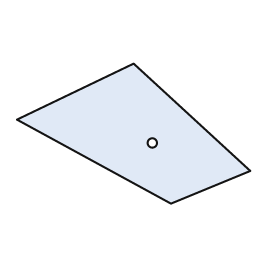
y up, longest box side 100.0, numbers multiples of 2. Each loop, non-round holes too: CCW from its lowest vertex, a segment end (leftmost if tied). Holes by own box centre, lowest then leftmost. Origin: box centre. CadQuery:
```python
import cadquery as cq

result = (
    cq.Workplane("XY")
    .moveTo(16.0, -30.0)
    .lineTo(50.0, -16.0)
    .lineTo(0.0, 30.0)
    .lineTo(-50.0, 6.0)
    .close()
    .moveTo(8.0, -4.0)
    .circle(2.0)
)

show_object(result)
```